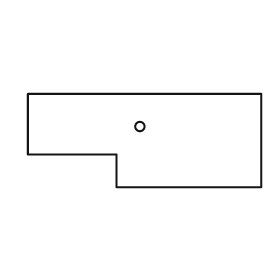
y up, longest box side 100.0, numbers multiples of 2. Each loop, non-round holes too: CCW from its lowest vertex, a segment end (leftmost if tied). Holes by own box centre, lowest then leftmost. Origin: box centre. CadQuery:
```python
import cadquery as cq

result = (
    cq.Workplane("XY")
    .moveTo(-12.0, -20.0)
    .lineTo(50.0, -20.0)
    .lineTo(50.0, 20.0)
    .lineTo(-50.0, 20.0)
    .lineTo(-50.0, -6.0)
    .lineTo(-12.0, -6.0)
    .close()
    .moveTo(-2.0, 6.0)
    .circle(2.0)
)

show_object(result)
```